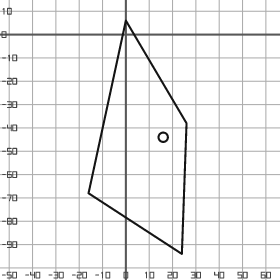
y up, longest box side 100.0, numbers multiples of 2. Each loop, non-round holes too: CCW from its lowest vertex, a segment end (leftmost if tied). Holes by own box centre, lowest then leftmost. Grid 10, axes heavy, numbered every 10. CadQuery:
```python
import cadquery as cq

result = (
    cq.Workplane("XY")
    .moveTo(24.0, -94.0)
    .lineTo(26.0, -38.0)
    .lineTo(0.0, 6.0)
    .lineTo(-16.0, -68.0)
    .close()
    .moveTo(16.0, -44.0)
    .circle(2.0)
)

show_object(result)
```